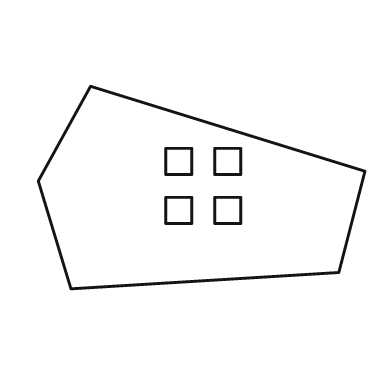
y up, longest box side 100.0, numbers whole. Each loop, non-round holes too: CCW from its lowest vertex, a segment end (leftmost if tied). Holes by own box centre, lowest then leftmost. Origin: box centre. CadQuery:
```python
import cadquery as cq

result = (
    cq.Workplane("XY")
    .moveTo(-40.0, -31.0)
    .lineTo(42.0, -26.0)
    .lineTo(50.0, 5.0)
    .lineTo(-34.0, 31.0)
    .lineTo(-50.0, 2.0)
    .close()
    .moveTo(-11.0, -11.0)
    .lineTo(-3.0, -11.0)
    .lineTo(-3.0, -3.0)
    .lineTo(-11.0, -3.0)
    .close()
    .moveTo(4.0, -11.0)
    .lineTo(12.0, -11.0)
    .lineTo(12.0, -3.0)
    .lineTo(4.0, -3.0)
    .close()
    .moveTo(-11.0, 4.0)
    .lineTo(-3.0, 4.0)
    .lineTo(-3.0, 12.0)
    .lineTo(-11.0, 12.0)
    .close()
    .moveTo(4.0, 4.0)
    .lineTo(12.0, 4.0)
    .lineTo(12.0, 12.0)
    .lineTo(4.0, 12.0)
    .close()
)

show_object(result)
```